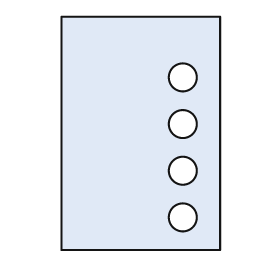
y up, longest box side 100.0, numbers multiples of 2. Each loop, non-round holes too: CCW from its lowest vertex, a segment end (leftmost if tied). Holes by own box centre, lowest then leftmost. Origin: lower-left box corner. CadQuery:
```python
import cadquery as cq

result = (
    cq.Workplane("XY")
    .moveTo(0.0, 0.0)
    .lineTo(68.0, 0.0)
    .lineTo(68.0, 100.0)
    .lineTo(0.0, 100.0)
    .close()
    .moveTo(52.0, 14.0)
    .circle(6.0)
    .moveTo(52.0, 34.0)
    .circle(6.0)
    .moveTo(52.0, 54.0)
    .circle(6.0)
    .moveTo(52.0, 74.0)
    .circle(6.0)
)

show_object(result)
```